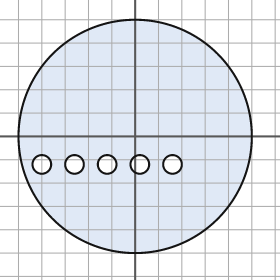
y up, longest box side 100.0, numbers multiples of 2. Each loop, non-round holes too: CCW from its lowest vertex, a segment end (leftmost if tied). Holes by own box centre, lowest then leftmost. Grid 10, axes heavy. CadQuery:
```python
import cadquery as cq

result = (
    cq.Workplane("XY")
    .moveTo(0.0, 0.0)
    .circle(50.0)
    .moveTo(-40.0, -12.0)
    .circle(4.0)
    .moveTo(-26.0, -12.0)
    .circle(4.0)
    .moveTo(-12.0, -12.0)
    .circle(4.0)
    .moveTo(2.0, -12.0)
    .circle(4.0)
    .moveTo(16.0, -12.0)
    .circle(4.0)
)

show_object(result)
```